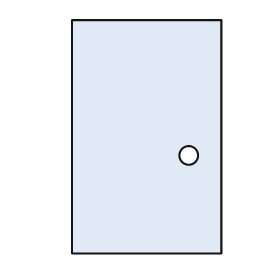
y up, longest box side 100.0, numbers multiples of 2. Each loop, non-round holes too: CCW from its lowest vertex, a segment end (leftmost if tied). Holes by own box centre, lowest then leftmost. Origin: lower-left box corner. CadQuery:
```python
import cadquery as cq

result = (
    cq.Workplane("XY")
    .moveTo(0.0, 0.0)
    .lineTo(64.0, 0.0)
    .lineTo(64.0, 100.0)
    .lineTo(0.0, 100.0)
    .close()
    .moveTo(50.0, 42.0)
    .circle(4.0)
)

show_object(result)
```